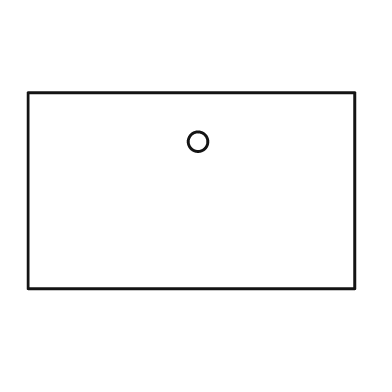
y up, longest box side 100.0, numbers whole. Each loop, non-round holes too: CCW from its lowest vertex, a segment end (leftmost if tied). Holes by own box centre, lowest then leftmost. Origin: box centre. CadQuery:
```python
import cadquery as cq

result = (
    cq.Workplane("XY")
    .moveTo(-50.0, -30.0)
    .lineTo(50.0, -30.0)
    .lineTo(50.0, 30.0)
    .lineTo(-50.0, 30.0)
    .close()
    .moveTo(2.0, 15.0)
    .circle(3.0)
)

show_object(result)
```